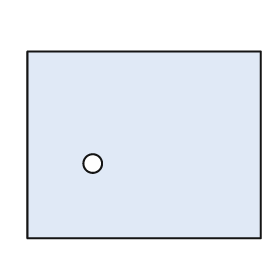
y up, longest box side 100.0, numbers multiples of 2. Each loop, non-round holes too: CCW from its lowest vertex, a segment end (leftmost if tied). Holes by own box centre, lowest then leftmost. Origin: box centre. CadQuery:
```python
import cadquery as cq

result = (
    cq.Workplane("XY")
    .moveTo(-50.0, -40.0)
    .lineTo(50.0, -40.0)
    .lineTo(50.0, 40.0)
    .lineTo(-50.0, 40.0)
    .close()
    .moveTo(-22.0, -8.0)
    .circle(4.0)
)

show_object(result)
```